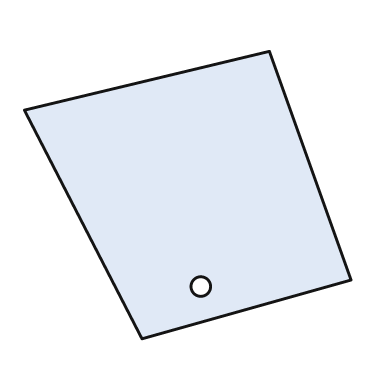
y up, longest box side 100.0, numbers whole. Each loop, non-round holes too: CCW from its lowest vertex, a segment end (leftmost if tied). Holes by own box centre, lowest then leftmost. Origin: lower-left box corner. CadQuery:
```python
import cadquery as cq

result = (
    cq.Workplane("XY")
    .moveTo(36.0, 0.0)
    .lineTo(100.0, 18.0)
    .lineTo(75.0, 88.0)
    .lineTo(0.0, 70.0)
    .close()
    .moveTo(54.0, 16.0)
    .circle(3.0)
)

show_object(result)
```